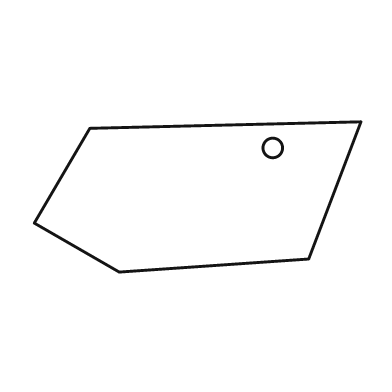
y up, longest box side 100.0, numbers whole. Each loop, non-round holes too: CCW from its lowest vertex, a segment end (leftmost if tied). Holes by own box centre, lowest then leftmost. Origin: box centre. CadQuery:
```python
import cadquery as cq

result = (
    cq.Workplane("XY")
    .moveTo(-24.0, -23.0)
    .lineTo(34.0, -19.0)
    .lineTo(50.0, 23.0)
    .lineTo(-33.0, 21.0)
    .lineTo(-50.0, -8.0)
    .close()
    .moveTo(23.0, 15.0)
    .circle(3.0)
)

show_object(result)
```